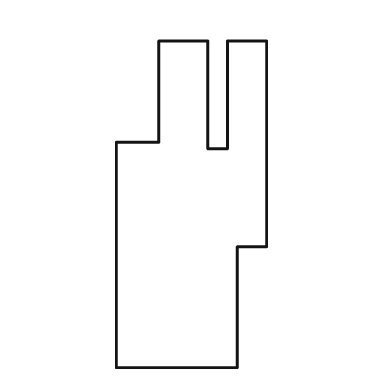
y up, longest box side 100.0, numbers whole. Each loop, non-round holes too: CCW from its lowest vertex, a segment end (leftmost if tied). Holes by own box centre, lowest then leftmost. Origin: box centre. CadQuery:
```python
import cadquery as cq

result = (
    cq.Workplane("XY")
    .moveTo(-23.0, -50.0)
    .lineTo(14.0, -50.0)
    .lineTo(14.0, -13.0)
    .lineTo(23.0, -13.0)
    .lineTo(23.0, 50.0)
    .lineTo(11.0, 50.0)
    .lineTo(11.0, 17.0)
    .lineTo(5.0, 17.0)
    .lineTo(5.0, 50.0)
    .lineTo(-10.0, 50.0)
    .lineTo(-10.0, 19.0)
    .lineTo(-23.0, 19.0)
    .close()
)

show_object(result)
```